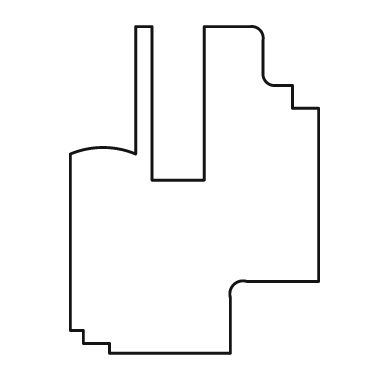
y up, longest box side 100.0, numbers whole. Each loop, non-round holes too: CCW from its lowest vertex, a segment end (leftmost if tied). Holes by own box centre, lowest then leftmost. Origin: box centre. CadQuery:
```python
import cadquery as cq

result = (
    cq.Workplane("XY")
    .moveTo(-26.0, -50.0)
    .lineTo(11.0, -50.0)
    .lineTo(11.0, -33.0)
    .threePointArc((12.0, -29.0), (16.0, -28.0))
    .lineTo(38.0, -28.0)
    .lineTo(38.0, 25.0)
    .lineTo(30.0, 25.0)
    .lineTo(30.0, 32.0)
    .lineTo(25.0, 32.0)
    .threePointArc((22.0, 33.0), (21.0, 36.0))
    .lineTo(21.0, 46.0)
    .threePointArc((20.0, 49.0), (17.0, 50.0))
    .lineTo(3.0, 50.0)
    .lineTo(3.0, 3.0)
    .lineTo(-13.0, 3.0)
    .lineTo(-13.0, 50.0)
    .lineTo(-18.0, 50.0)
    .lineTo(-18.0, 11.0)
    .threePointArc((-28.0, 13.0), (-38.0, 11.0))
    .lineTo(-38.0, -43.0)
    .lineTo(-34.0, -43.0)
    .lineTo(-34.0, -47.0)
    .lineTo(-26.0, -47.0)
    .close()
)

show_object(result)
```